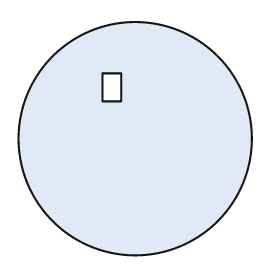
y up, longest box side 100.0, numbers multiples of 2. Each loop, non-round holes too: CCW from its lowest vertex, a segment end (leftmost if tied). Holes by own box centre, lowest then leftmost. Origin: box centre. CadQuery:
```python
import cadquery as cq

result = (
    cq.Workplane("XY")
    .moveTo(0.0, 0.0)
    .circle(50.0)
    .moveTo(-14.0, 16.0)
    .lineTo(-6.0, 16.0)
    .lineTo(-6.0, 28.0)
    .lineTo(-14.0, 28.0)
    .close()
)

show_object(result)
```